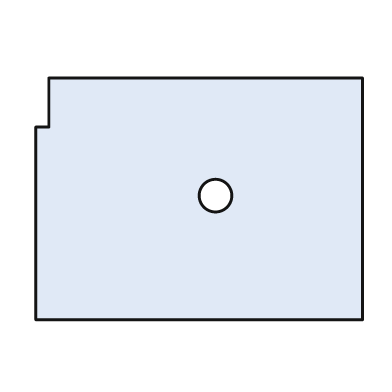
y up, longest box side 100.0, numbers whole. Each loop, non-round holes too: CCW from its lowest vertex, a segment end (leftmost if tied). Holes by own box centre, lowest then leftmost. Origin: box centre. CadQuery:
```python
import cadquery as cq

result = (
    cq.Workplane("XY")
    .moveTo(-50.0, -37.0)
    .lineTo(50.0, -37.0)
    .lineTo(50.0, 37.0)
    .lineTo(-46.0, 37.0)
    .lineTo(-46.0, 22.0)
    .lineTo(-50.0, 22.0)
    .close()
    .moveTo(5.0, 1.0)
    .circle(5.0)
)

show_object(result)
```